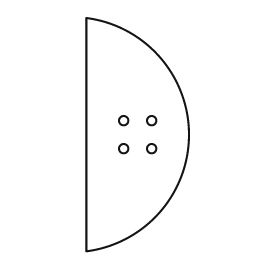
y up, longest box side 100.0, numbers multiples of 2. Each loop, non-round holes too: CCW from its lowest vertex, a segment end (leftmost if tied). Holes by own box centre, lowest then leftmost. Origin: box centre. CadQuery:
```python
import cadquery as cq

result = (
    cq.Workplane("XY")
    .moveTo(-22.0, -50.0)
    .threePointArc((22.0, 0.0), (-22.0, 50.0))
    .close()
    .moveTo(-6.0, -6.0)
    .circle(2.0)
    .moveTo(6.0, -6.0)
    .circle(2.0)
    .moveTo(-6.0, 6.0)
    .circle(2.0)
    .moveTo(6.0, 6.0)
    .circle(2.0)
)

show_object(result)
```